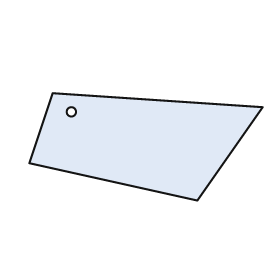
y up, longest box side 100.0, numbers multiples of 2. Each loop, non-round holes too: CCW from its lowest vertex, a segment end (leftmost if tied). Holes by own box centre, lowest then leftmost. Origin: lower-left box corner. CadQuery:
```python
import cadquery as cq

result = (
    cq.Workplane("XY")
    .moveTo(72.0, 0.0)
    .lineTo(100.0, 40.0)
    .lineTo(10.0, 46.0)
    .lineTo(0.0, 16.0)
    .close()
    .moveTo(18.0, 38.0)
    .circle(2.0)
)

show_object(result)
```